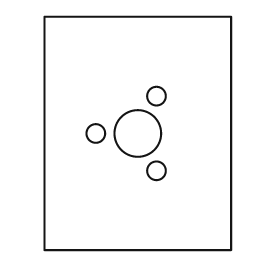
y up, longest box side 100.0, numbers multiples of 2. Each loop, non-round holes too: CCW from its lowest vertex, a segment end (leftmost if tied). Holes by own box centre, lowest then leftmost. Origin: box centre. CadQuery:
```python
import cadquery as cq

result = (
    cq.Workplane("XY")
    .moveTo(-40.0, -50.0)
    .lineTo(40.0, -50.0)
    .lineTo(40.0, 50.0)
    .lineTo(-40.0, 50.0)
    .close()
    .moveTo(8.0, -16.0)
    .circle(4.0)
    .moveTo(-18.0, 0.0)
    .circle(4.0)
    .moveTo(0.0, 0.0)
    .circle(10.0)
    .moveTo(8.0, 16.0)
    .circle(4.0)
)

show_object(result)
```